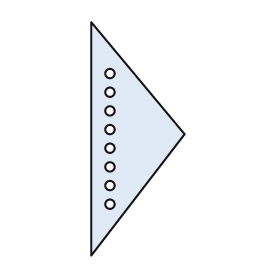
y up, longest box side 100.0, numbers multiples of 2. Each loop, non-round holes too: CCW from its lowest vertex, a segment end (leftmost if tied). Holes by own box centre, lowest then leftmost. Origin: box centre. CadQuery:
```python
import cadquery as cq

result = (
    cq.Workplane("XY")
    .moveTo(-20.0, -50.0)
    .lineTo(20.0, 2.0)
    .lineTo(-20.0, 50.0)
    .close()
    .moveTo(-12.0, -28.0)
    .circle(2.0)
    .moveTo(-12.0, -20.0)
    .circle(2.0)
    .moveTo(-12.0, -12.0)
    .circle(2.0)
    .moveTo(-12.0, -4.0)
    .circle(2.0)
    .moveTo(-12.0, 4.0)
    .circle(2.0)
    .moveTo(-12.0, 12.0)
    .circle(2.0)
    .moveTo(-12.0, 20.0)
    .circle(2.0)
    .moveTo(-12.0, 28.0)
    .circle(2.0)
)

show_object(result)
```